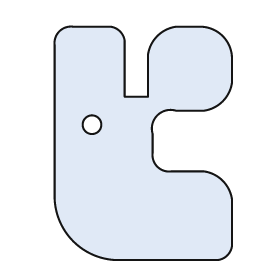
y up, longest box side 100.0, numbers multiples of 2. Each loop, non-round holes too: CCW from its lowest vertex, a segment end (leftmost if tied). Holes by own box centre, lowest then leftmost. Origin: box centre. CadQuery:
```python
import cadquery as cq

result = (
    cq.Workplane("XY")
    .moveTo(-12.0, -50.0)
    .lineTo(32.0, -50.0)
    .threePointArc((36.0, -48.0), (38.0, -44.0))
    .lineTo(38.0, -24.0)
    .threePointArc((34.0, -16.0), (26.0, -12.0))
    .lineTo(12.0, -12.0)
    .threePointArc((6.0, -10.0), (4.0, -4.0))
    .lineTo(4.0, 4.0)
    .threePointArc((6.0, 12.0), (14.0, 14.0))
    .lineTo(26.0, 14.0)
    .threePointArc((34.0, 18.0), (38.0, 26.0))
    .lineTo(38.0, 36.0)
    .threePointArc((34.0, 46.0), (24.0, 50.0))
    .lineTo(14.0, 50.0)
    .threePointArc((6.0, 46.0), (2.0, 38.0))
    .lineTo(2.0, 20.0)
    .lineTo(-8.0, 20.0)
    .lineTo(-8.0, 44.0)
    .threePointArc((-10.0, 48.0), (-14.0, 50.0))
    .lineTo(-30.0, 50.0)
    .threePointArc((-36.0, 48.0), (-38.0, 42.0))
    .lineTo(-38.0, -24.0)
    .threePointArc((-30.0, -42.0), (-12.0, -50.0))
    .close()
    .moveTo(-22.0, 8.0)
    .circle(4.0)
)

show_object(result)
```